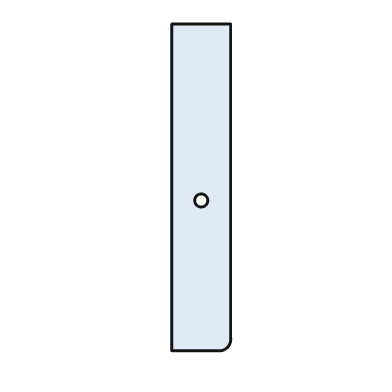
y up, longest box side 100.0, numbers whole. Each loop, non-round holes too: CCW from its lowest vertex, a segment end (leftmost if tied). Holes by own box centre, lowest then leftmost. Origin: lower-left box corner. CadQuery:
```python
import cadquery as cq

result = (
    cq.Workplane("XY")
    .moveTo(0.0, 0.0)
    .lineTo(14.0, 0.0)
    .threePointArc((17.0, 1.0), (18.0, 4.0))
    .lineTo(18.0, 100.0)
    .lineTo(0.0, 100.0)
    .close()
    .moveTo(9.0, 46.0)
    .circle(2.0)
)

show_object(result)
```